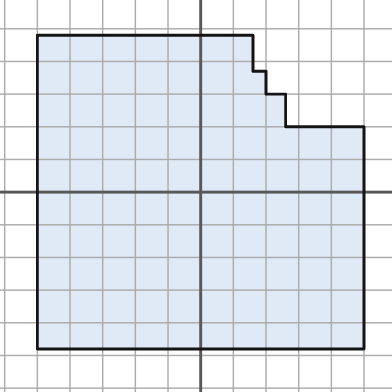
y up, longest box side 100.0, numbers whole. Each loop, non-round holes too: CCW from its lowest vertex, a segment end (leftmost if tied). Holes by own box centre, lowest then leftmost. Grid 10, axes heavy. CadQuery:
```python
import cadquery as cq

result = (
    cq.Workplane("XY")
    .moveTo(-50.0, -48.0)
    .lineTo(50.0, -48.0)
    .lineTo(50.0, 20.0)
    .lineTo(26.0, 20.0)
    .lineTo(26.0, 30.0)
    .lineTo(20.0, 30.0)
    .lineTo(20.0, 37.0)
    .lineTo(16.0, 37.0)
    .lineTo(16.0, 48.0)
    .lineTo(-50.0, 48.0)
    .close()
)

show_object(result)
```